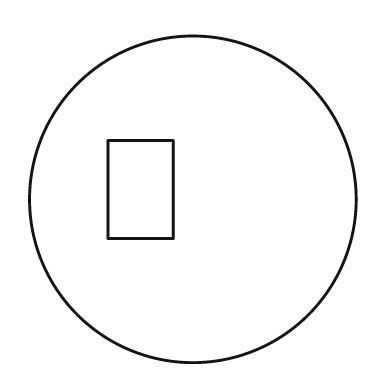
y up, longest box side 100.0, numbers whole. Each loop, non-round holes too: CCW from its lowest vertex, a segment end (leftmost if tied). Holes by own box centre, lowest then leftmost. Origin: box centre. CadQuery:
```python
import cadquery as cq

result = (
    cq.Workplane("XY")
    .moveTo(0.0, 0.0)
    .circle(50.0)
    .moveTo(-26.0, -12.0)
    .lineTo(-6.0, -12.0)
    .lineTo(-6.0, 18.0)
    .lineTo(-26.0, 18.0)
    .close()
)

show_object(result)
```